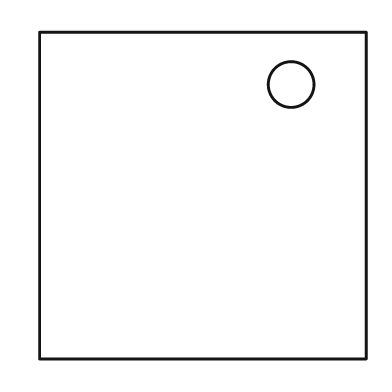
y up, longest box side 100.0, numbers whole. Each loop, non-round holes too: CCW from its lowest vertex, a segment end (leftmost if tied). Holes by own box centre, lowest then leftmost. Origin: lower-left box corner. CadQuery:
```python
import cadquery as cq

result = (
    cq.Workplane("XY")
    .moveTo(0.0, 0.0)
    .lineTo(100.0, 0.0)
    .lineTo(100.0, 100.0)
    .lineTo(0.0, 100.0)
    .close()
    .moveTo(77.0, 84.0)
    .circle(7.0)
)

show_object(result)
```